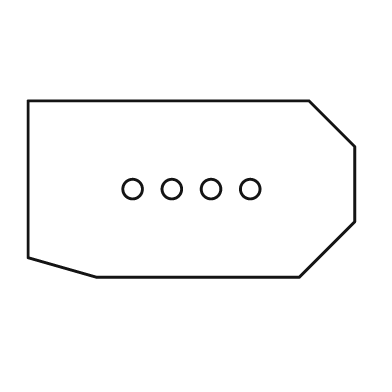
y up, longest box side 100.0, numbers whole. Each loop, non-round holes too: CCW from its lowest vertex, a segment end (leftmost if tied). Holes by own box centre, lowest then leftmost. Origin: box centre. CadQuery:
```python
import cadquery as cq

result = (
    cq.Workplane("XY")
    .moveTo(-29.0, -27.0)
    .lineTo(33.0, -27.0)
    .lineTo(50.0, -10.0)
    .lineTo(50.0, 13.0)
    .lineTo(36.0, 27.0)
    .lineTo(-50.0, 27.0)
    .lineTo(-50.0, -21.0)
    .close()
    .moveTo(-18.0, 0.0)
    .circle(3.0)
    .moveTo(-6.0, 0.0)
    .circle(3.0)
    .moveTo(6.0, 0.0)
    .circle(3.0)
    .moveTo(18.0, 0.0)
    .circle(3.0)
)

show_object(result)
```